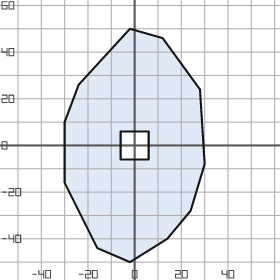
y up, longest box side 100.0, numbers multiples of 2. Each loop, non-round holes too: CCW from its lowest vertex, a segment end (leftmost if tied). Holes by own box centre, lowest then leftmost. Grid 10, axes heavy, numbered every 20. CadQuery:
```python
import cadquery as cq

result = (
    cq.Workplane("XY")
    .moveTo(-2.0, -50.0)
    .lineTo(14.0, -40.0)
    .lineTo(24.0, -28.0)
    .lineTo(30.0, -8.0)
    .lineTo(28.0, 24.0)
    .lineTo(12.0, 46.0)
    .lineTo(-2.0, 50.0)
    .lineTo(-24.0, 26.0)
    .lineTo(-30.0, 10.0)
    .lineTo(-30.0, -16.0)
    .lineTo(-16.0, -44.0)
    .close()
    .moveTo(-6.0, -6.0)
    .lineTo(6.0, -6.0)
    .lineTo(6.0, 6.0)
    .lineTo(-6.0, 6.0)
    .close()
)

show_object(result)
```